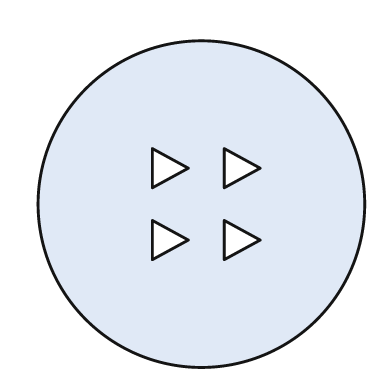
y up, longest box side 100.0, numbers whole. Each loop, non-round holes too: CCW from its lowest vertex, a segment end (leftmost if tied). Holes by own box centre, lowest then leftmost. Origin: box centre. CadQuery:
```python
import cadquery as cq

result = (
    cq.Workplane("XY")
    .moveTo(0.0, 0.0)
    .circle(50.0)
    .moveTo(-15.0, -17.0)
    .lineTo(-4.0, -11.0)
    .lineTo(-15.0, -5.0)
    .close()
    .moveTo(7.0, -17.0)
    .lineTo(18.0, -11.0)
    .lineTo(7.0, -5.0)
    .close()
    .moveTo(-15.0, 5.0)
    .lineTo(-4.0, 11.0)
    .lineTo(-15.0, 17.0)
    .close()
    .moveTo(7.0, 5.0)
    .lineTo(18.0, 11.0)
    .lineTo(7.0, 17.0)
    .close()
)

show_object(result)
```